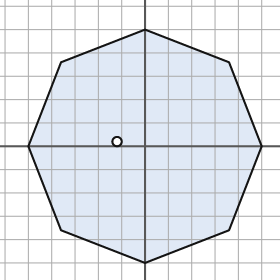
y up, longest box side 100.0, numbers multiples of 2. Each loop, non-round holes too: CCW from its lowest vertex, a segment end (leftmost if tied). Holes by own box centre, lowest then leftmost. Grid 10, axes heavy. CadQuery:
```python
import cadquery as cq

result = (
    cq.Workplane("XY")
    .moveTo(0.0, -50.0)
    .lineTo(36.0, -36.0)
    .lineTo(50.0, 0.0)
    .lineTo(36.0, 36.0)
    .lineTo(0.0, 50.0)
    .lineTo(-36.0, 36.0)
    .lineTo(-50.0, 0.0)
    .lineTo(-36.0, -36.0)
    .close()
    .moveTo(-12.0, 2.0)
    .circle(2.0)
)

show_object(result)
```